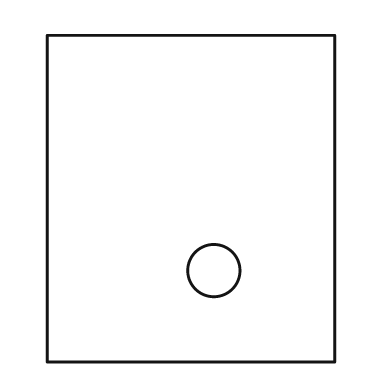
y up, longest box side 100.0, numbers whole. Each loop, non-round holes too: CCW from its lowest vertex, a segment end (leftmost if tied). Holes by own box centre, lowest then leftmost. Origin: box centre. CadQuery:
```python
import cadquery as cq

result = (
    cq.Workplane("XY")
    .moveTo(-44.0, -50.0)
    .lineTo(44.0, -50.0)
    .lineTo(44.0, 50.0)
    .lineTo(-44.0, 50.0)
    .close()
    .moveTo(7.0, -22.0)
    .circle(8.0)
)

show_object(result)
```